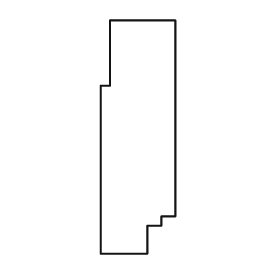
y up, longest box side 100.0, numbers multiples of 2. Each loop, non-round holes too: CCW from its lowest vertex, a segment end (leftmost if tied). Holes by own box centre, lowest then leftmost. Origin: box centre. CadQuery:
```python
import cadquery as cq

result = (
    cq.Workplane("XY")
    .moveTo(-16.0, -50.0)
    .lineTo(4.0, -50.0)
    .lineTo(4.0, -38.0)
    .lineTo(10.0, -38.0)
    .lineTo(10.0, -34.0)
    .lineTo(16.0, -34.0)
    .lineTo(16.0, 50.0)
    .lineTo(-12.0, 50.0)
    .lineTo(-12.0, 22.0)
    .lineTo(-16.0, 22.0)
    .close()
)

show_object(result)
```